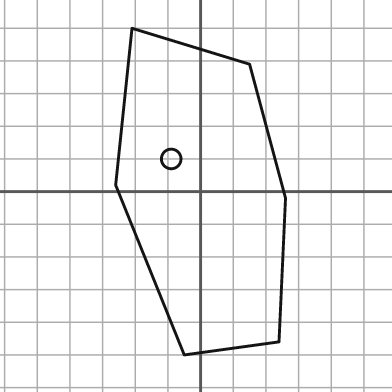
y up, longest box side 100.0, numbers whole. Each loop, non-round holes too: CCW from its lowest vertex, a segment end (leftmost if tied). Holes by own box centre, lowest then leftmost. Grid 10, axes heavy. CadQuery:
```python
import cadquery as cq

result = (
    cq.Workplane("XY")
    .moveTo(-5.0, -50.0)
    .lineTo(24.0, -46.0)
    .lineTo(26.0, -2.0)
    .lineTo(15.0, 39.0)
    .lineTo(-21.0, 50.0)
    .lineTo(-26.0, 2.0)
    .close()
    .moveTo(-9.0, 10.0)
    .circle(3.0)
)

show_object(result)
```